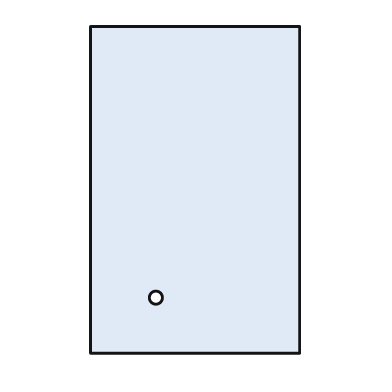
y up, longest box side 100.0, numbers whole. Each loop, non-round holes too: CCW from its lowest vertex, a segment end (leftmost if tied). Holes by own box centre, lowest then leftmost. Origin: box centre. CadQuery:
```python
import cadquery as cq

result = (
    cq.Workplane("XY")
    .moveTo(-32.0, -50.0)
    .lineTo(32.0, -50.0)
    .lineTo(32.0, 50.0)
    .lineTo(-32.0, 50.0)
    .close()
    .moveTo(-12.0, -33.0)
    .circle(2.0)
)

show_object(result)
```